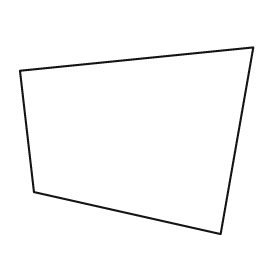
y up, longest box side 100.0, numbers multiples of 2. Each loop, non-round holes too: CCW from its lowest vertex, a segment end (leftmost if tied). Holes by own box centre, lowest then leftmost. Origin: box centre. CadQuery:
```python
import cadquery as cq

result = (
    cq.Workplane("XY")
    .moveTo(36.0, -40.0)
    .lineTo(50.0, 40.0)
    .lineTo(-50.0, 30.0)
    .lineTo(-44.0, -22.0)
    .close()
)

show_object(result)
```